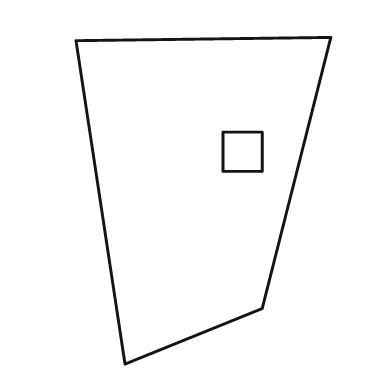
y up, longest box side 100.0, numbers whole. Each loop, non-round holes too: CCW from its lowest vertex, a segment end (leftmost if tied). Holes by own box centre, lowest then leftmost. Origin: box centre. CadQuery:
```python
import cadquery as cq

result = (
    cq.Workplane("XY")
    .moveTo(-24.0, -50.0)
    .lineTo(18.0, -33.0)
    .lineTo(39.0, 50.0)
    .lineTo(-39.0, 49.0)
    .close()
    .moveTo(6.0, 9.0)
    .lineTo(18.0, 9.0)
    .lineTo(18.0, 21.0)
    .lineTo(6.0, 21.0)
    .close()
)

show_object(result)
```